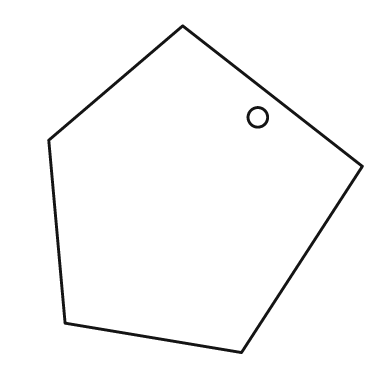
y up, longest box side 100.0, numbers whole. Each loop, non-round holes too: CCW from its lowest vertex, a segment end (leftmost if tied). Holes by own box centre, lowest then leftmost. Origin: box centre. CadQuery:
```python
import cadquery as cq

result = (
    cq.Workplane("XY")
    .moveTo(11.0, -50.0)
    .lineTo(48.0, 7.0)
    .lineTo(-7.0, 50.0)
    .lineTo(-48.0, 15.0)
    .lineTo(-43.0, -41.0)
    .close()
    .moveTo(16.0, 22.0)
    .circle(3.0)
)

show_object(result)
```